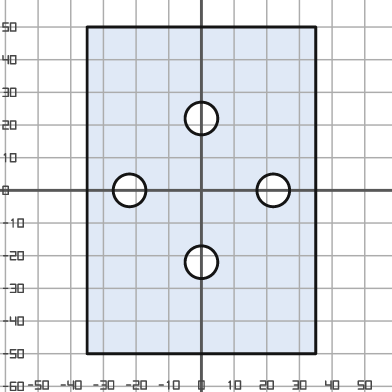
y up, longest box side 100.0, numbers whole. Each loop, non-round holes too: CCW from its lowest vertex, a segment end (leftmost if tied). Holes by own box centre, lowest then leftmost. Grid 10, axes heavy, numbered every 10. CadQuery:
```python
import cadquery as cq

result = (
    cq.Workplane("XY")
    .moveTo(-35.0, -50.0)
    .lineTo(35.0, -50.0)
    .lineTo(35.0, 50.0)
    .lineTo(-35.0, 50.0)
    .close()
    .moveTo(0.0, -22.0)
    .circle(5.0)
    .moveTo(-22.0, 0.0)
    .circle(5.0)
    .moveTo(22.0, 0.0)
    .circle(5.0)
    .moveTo(0.0, 22.0)
    .circle(5.0)
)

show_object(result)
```